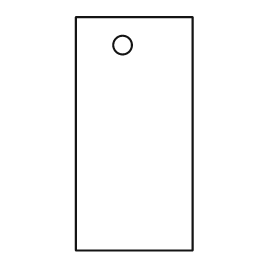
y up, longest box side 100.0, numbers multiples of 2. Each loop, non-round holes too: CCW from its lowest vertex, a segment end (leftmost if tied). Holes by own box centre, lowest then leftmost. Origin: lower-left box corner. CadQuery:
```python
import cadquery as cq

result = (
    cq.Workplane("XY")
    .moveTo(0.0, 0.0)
    .lineTo(50.0, 0.0)
    .lineTo(50.0, 100.0)
    .lineTo(0.0, 100.0)
    .close()
    .moveTo(20.0, 88.0)
    .circle(4.0)
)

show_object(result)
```